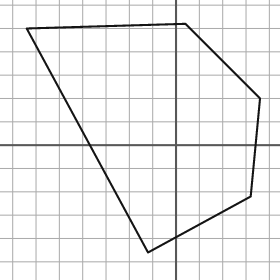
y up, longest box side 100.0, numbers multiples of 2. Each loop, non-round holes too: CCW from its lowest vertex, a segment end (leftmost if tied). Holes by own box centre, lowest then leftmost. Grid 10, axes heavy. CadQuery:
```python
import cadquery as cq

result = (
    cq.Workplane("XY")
    .moveTo(-12.0, -46.0)
    .lineTo(32.0, -22.0)
    .lineTo(36.0, 20.0)
    .lineTo(4.0, 52.0)
    .lineTo(-64.0, 50.0)
    .close()
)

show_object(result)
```